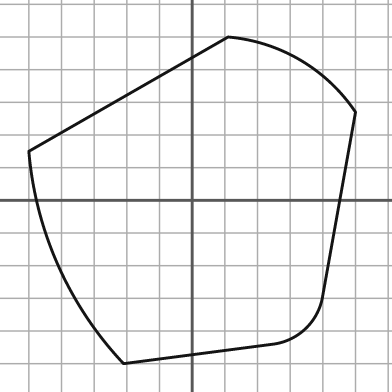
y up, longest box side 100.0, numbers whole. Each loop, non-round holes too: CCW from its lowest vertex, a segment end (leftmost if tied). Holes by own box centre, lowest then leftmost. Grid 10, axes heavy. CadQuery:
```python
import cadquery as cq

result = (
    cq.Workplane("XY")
    .moveTo(-21.0, -50.0)
    .lineTo(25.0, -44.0)
    .threePointArc((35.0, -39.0), (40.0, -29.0))
    .lineTo(50.0, 27.0)
    .threePointArc((33.0, 43.0), (11.0, 50.0))
    .lineTo(-50.0, 15.0)
    .threePointArc((-41.0, -20.0), (-21.0, -50.0))
    .close()
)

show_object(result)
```